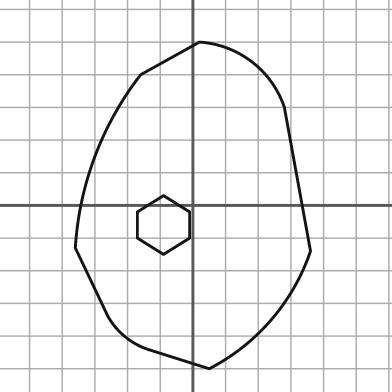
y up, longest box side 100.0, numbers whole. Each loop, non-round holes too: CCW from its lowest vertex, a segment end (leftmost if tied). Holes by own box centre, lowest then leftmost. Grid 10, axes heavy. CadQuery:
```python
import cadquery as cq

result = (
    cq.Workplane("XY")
    .moveTo(5.0, -50.0)
    .threePointArc((24.0, -35.0), (36.0, -14.0))
    .lineTo(28.0, 30.0)
    .threePointArc((18.0, 44.0), (2.0, 50.0))
    .lineTo(-16.0, 40.0)
    .threePointArc((-30.0, 15.0), (-36.0, -13.0))
    .lineTo(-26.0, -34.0)
    .threePointArc((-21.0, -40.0), (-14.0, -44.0))
    .close()
    .moveTo(-9.0, -15.0)
    .lineTo(-1.0, -10.0)
    .lineTo(-1.0, -2.0)
    .lineTo(-9.0, 3.0)
    .lineTo(-17.0, -2.0)
    .lineTo(-17.0, -10.0)
    .close()
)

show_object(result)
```